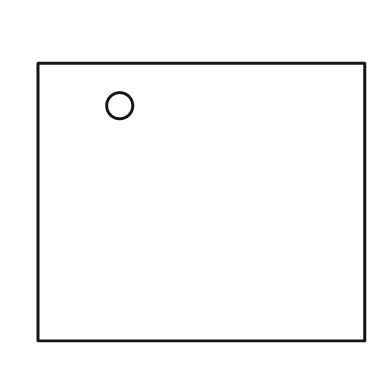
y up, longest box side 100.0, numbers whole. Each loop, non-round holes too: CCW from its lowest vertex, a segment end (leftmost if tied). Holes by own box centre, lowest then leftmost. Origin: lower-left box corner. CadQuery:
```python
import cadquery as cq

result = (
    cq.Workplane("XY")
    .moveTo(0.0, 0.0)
    .lineTo(100.0, 0.0)
    .lineTo(100.0, 85.0)
    .lineTo(0.0, 85.0)
    .close()
    .moveTo(25.0, 72.0)
    .circle(4.0)
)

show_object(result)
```